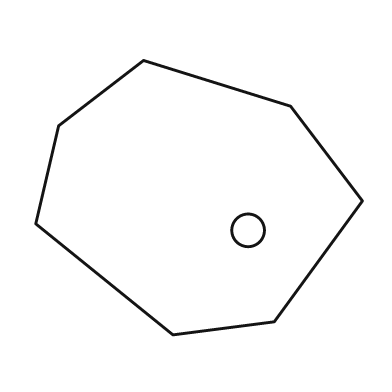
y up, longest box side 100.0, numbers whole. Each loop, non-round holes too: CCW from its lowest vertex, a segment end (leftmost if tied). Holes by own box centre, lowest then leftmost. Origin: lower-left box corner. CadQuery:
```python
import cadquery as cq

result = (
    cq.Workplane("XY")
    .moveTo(42.0, 0.0)
    .lineTo(73.0, 4.0)
    .lineTo(100.0, 41.0)
    .lineTo(78.0, 70.0)
    .lineTo(33.0, 84.0)
    .lineTo(7.0, 64.0)
    .lineTo(0.0, 34.0)
    .close()
    .moveTo(65.0, 32.0)
    .circle(5.0)
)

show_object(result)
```